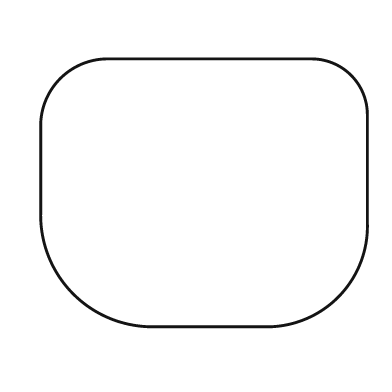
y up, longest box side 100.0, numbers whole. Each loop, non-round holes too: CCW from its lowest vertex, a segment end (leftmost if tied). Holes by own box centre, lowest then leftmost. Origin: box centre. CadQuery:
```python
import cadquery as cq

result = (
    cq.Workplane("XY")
    .moveTo(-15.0, -41.0)
    .lineTo(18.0, -41.0)
    .threePointArc((41.0, -32.0), (50.0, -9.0))
    .lineTo(50.0, 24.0)
    .threePointArc((45.0, 36.0), (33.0, 41.0))
    .lineTo(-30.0, 41.0)
    .threePointArc((-44.0, 35.0), (-50.0, 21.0))
    .lineTo(-50.0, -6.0)
    .threePointArc((-40.0, -31.0), (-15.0, -41.0))
    .close()
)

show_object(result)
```